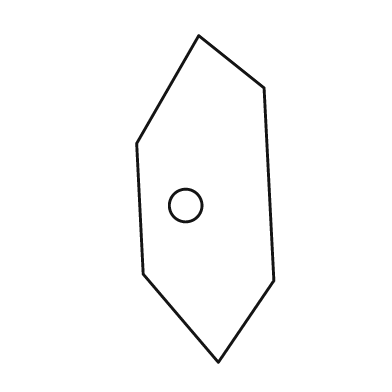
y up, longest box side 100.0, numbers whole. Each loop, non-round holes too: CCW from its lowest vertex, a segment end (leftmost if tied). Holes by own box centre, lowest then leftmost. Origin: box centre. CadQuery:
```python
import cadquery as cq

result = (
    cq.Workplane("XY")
    .moveTo(4.0, -50.0)
    .lineTo(21.0, -25.0)
    .lineTo(18.0, 34.0)
    .lineTo(-2.0, 50.0)
    .lineTo(-21.0, 17.0)
    .lineTo(-19.0, -23.0)
    .close()
    .moveTo(-6.0, -2.0)
    .circle(5.0)
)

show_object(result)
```